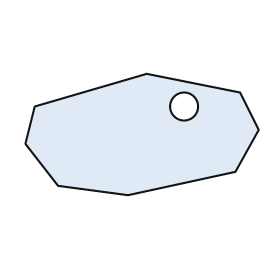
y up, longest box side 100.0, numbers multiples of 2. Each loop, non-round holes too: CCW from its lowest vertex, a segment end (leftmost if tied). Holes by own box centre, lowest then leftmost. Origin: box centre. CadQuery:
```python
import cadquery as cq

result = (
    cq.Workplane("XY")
    .moveTo(-6.0, -26.0)
    .lineTo(40.0, -16.0)
    .lineTo(50.0, 2.0)
    .lineTo(42.0, 18.0)
    .lineTo(2.0, 26.0)
    .lineTo(-46.0, 12.0)
    .lineTo(-50.0, -4.0)
    .lineTo(-36.0, -22.0)
    .close()
    .moveTo(18.0, 12.0)
    .circle(6.0)
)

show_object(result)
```